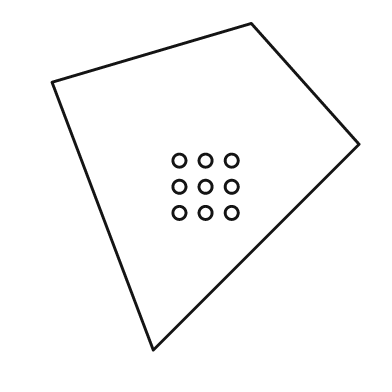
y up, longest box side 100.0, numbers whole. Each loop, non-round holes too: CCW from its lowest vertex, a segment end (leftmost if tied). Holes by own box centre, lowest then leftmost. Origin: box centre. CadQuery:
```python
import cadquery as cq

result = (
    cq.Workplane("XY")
    .moveTo(-16.0, -50.0)
    .lineTo(47.0, 13.0)
    .lineTo(14.0, 50.0)
    .lineTo(-47.0, 32.0)
    .close()
    .moveTo(-8.0, -8.0)
    .circle(2.0)
    .moveTo(0.0, -8.0)
    .circle(2.0)
    .moveTo(8.0, -8.0)
    .circle(2.0)
    .moveTo(-8.0, 0.0)
    .circle(2.0)
    .moveTo(0.0, 0.0)
    .circle(2.0)
    .moveTo(8.0, 0.0)
    .circle(2.0)
    .moveTo(-8.0, 8.0)
    .circle(2.0)
    .moveTo(0.0, 8.0)
    .circle(2.0)
    .moveTo(8.0, 8.0)
    .circle(2.0)
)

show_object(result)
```